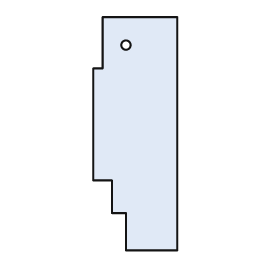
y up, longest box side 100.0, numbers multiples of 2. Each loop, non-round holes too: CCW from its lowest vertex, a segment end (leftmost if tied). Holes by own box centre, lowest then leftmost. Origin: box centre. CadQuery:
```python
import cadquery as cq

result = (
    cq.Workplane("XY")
    .moveTo(-4.0, -50.0)
    .lineTo(18.0, -50.0)
    .lineTo(18.0, 50.0)
    .lineTo(-14.0, 50.0)
    .lineTo(-14.0, 28.0)
    .lineTo(-18.0, 28.0)
    .lineTo(-18.0, -20.0)
    .lineTo(-10.0, -20.0)
    .lineTo(-10.0, -34.0)
    .lineTo(-4.0, -34.0)
    .close()
    .moveTo(-4.0, 38.0)
    .circle(2.0)
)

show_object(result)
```